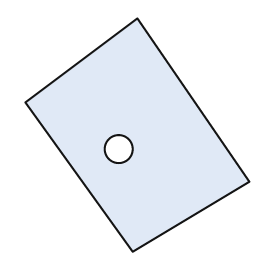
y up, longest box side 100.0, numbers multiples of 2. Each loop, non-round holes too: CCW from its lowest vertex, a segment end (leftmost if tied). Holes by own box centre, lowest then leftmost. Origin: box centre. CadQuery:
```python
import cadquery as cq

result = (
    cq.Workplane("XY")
    .moveTo(-2.0, -50.0)
    .lineTo(48.0, -20.0)
    .lineTo(0.0, 50.0)
    .lineTo(-48.0, 14.0)
    .close()
    .moveTo(-8.0, -6.0)
    .circle(6.0)
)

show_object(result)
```